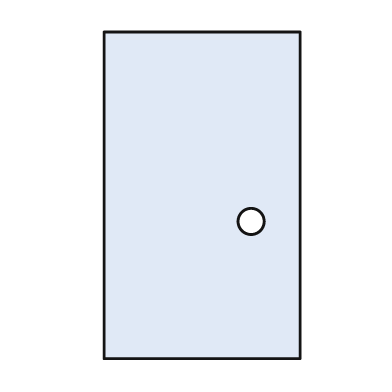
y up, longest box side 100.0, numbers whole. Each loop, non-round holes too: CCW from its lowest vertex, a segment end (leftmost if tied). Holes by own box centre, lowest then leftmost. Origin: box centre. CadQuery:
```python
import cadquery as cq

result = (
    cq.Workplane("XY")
    .moveTo(-30.0, -50.0)
    .lineTo(30.0, -50.0)
    .lineTo(30.0, 50.0)
    .lineTo(-30.0, 50.0)
    .close()
    .moveTo(15.0, -8.0)
    .circle(4.0)
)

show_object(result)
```